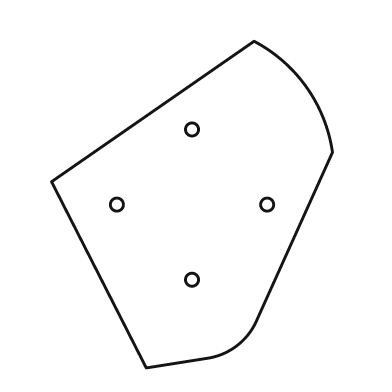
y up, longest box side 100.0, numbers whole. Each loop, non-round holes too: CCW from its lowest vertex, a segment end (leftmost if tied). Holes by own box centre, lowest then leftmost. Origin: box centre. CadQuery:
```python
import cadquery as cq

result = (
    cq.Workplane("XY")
    .moveTo(-14.0, -50.0)
    .lineTo(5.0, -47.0)
    .threePointArc((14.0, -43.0), (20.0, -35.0))
    .lineTo(43.0, 16.0)
    .threePointArc((35.0, 36.0), (19.0, 50.0))
    .lineTo(-43.0, 7.0)
    .close()
    .moveTo(0.0, -23.0)
    .circle(2.0)
    .moveTo(-23.0, 0.0)
    .circle(2.0)
    .moveTo(23.0, 0.0)
    .circle(2.0)
    .moveTo(0.0, 23.0)
    .circle(2.0)
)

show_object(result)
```